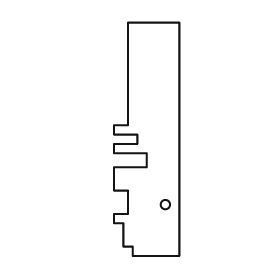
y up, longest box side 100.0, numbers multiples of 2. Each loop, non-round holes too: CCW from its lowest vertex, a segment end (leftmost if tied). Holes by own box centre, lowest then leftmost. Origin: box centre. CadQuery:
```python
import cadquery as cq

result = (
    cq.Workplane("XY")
    .moveTo(-6.0, -50.0)
    .lineTo(14.0, -50.0)
    .lineTo(14.0, 50.0)
    .lineTo(-8.0, 50.0)
    .lineTo(-8.0, 6.0)
    .lineTo(-14.0, 6.0)
    .lineTo(-14.0, 2.0)
    .lineTo(-4.0, 2.0)
    .lineTo(-4.0, -2.0)
    .lineTo(-14.0, -2.0)
    .lineTo(-14.0, -6.0)
    .lineTo(0.0, -6.0)
    .lineTo(0.0, -12.0)
    .lineTo(-14.0, -12.0)
    .lineTo(-14.0, -22.0)
    .lineTo(-8.0, -22.0)
    .lineTo(-8.0, -32.0)
    .lineTo(-14.0, -32.0)
    .lineTo(-14.0, -36.0)
    .lineTo(-10.0, -36.0)
    .lineTo(-10.0, -46.0)
    .lineTo(-6.0, -46.0)
    .close()
    .moveTo(8.0, -28.0)
    .circle(2.0)
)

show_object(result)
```